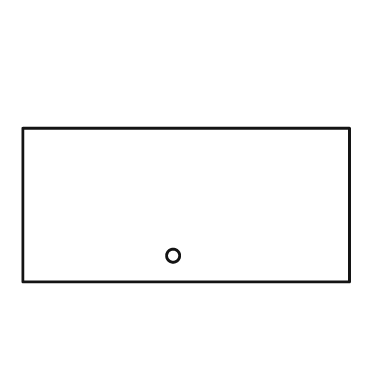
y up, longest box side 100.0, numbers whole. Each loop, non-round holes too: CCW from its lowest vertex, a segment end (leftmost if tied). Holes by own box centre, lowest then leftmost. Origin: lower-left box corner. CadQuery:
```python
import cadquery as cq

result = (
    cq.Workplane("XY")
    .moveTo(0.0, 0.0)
    .lineTo(100.0, 0.0)
    .lineTo(100.0, 47.0)
    .lineTo(0.0, 47.0)
    .close()
    .moveTo(46.0, 8.0)
    .circle(2.0)
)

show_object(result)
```